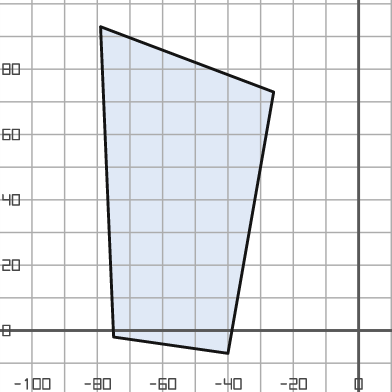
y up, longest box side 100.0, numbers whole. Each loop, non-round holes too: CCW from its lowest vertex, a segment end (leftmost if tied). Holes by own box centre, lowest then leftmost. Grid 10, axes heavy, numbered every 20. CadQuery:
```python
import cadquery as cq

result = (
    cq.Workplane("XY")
    .moveTo(-40.0, -7.0)
    .lineTo(-26.0, 73.0)
    .lineTo(-79.0, 93.0)
    .lineTo(-75.0, -2.0)
    .close()
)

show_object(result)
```